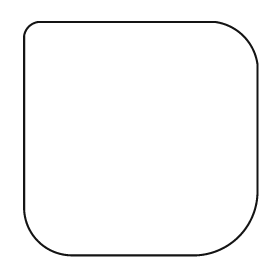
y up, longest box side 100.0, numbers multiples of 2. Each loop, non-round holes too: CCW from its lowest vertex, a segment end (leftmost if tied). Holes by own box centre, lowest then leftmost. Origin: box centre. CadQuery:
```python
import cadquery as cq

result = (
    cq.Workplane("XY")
    .moveTo(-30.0, -50.0)
    .lineTo(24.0, -50.0)
    .threePointArc((42.0, -42.0), (50.0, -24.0))
    .lineTo(50.0, 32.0)
    .threePointArc((44.0, 44.0), (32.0, 50.0))
    .lineTo(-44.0, 50.0)
    .threePointArc((-48.0, 48.0), (-50.0, 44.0))
    .lineTo(-50.0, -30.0)
    .threePointArc((-44.0, -44.0), (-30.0, -50.0))
    .close()
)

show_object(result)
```